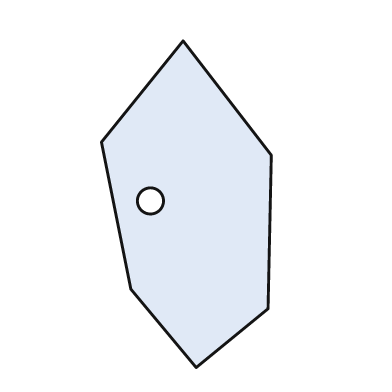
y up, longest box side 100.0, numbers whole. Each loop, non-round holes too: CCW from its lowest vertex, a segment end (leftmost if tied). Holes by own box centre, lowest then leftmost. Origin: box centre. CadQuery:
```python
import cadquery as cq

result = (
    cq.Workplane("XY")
    .moveTo(3.0, -50.0)
    .lineTo(25.0, -32.0)
    .lineTo(26.0, 15.0)
    .lineTo(-1.0, 50.0)
    .lineTo(-26.0, 19.0)
    .lineTo(-17.0, -26.0)
    .close()
    .moveTo(-11.0, 1.0)
    .circle(4.0)
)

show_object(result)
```